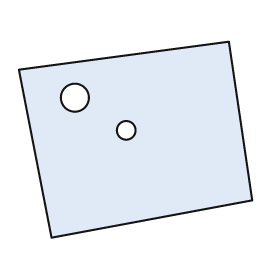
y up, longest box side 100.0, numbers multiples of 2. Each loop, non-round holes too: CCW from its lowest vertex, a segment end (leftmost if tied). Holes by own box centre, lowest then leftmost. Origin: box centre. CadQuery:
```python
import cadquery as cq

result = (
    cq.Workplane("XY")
    .moveTo(-36.0, -42.0)
    .lineTo(50.0, -26.0)
    .lineTo(40.0, 42.0)
    .lineTo(-50.0, 30.0)
    .close()
    .moveTo(-4.0, 4.0)
    .circle(4.0)
    .moveTo(-26.0, 18.0)
    .circle(6.0)
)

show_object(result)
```